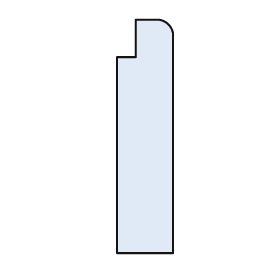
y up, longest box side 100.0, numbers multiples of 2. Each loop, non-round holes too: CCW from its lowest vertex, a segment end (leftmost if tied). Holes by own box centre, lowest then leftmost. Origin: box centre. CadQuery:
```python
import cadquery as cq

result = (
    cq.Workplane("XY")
    .moveTo(-12.0, -50.0)
    .lineTo(12.0, -50.0)
    .lineTo(12.0, 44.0)
    .threePointArc((10.0, 48.0), (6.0, 50.0))
    .lineTo(-4.0, 50.0)
    .lineTo(-4.0, 34.0)
    .lineTo(-12.0, 34.0)
    .close()
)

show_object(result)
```